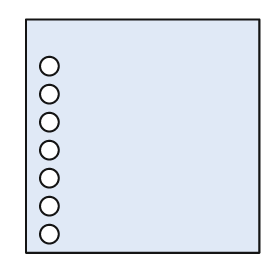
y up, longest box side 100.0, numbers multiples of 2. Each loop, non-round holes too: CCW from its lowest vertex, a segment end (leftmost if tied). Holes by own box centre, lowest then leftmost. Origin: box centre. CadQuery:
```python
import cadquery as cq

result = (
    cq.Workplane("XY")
    .moveTo(-50.0, -50.0)
    .lineTo(50.0, -50.0)
    .lineTo(50.0, 50.0)
    .lineTo(-50.0, 50.0)
    .close()
    .moveTo(-40.0, -42.0)
    .circle(4.0)
    .moveTo(-40.0, -30.0)
    .circle(4.0)
    .moveTo(-40.0, -18.0)
    .circle(4.0)
    .moveTo(-40.0, -6.0)
    .circle(4.0)
    .moveTo(-40.0, 6.0)
    .circle(4.0)
    .moveTo(-40.0, 18.0)
    .circle(4.0)
    .moveTo(-40.0, 30.0)
    .circle(4.0)
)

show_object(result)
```